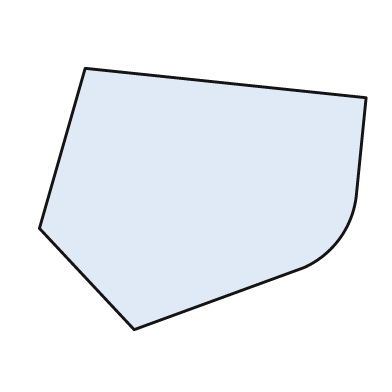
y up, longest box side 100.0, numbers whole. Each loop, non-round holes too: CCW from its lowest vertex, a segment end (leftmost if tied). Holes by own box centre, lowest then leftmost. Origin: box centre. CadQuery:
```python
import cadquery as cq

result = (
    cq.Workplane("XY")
    .moveTo(-21.0, -40.0)
    .lineTo(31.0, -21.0)
    .threePointArc((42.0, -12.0), (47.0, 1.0))
    .lineTo(50.0, 31.0)
    .lineTo(-36.0, 40.0)
    .lineTo(-50.0, -9.0)
    .close()
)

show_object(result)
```